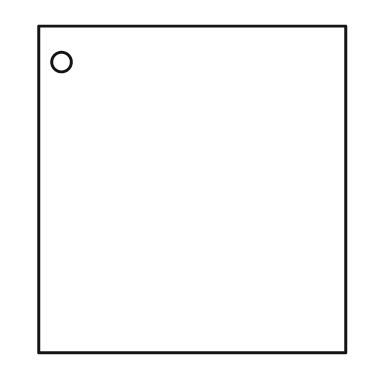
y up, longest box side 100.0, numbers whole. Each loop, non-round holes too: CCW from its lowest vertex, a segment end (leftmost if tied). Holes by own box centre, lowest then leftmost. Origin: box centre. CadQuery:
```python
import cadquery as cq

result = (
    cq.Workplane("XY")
    .moveTo(-47.0, -50.0)
    .lineTo(47.0, -50.0)
    .lineTo(47.0, 50.0)
    .lineTo(-47.0, 50.0)
    .close()
    .moveTo(-40.0, 39.0)
    .circle(3.0)
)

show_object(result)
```